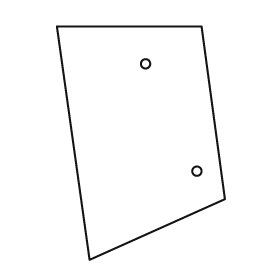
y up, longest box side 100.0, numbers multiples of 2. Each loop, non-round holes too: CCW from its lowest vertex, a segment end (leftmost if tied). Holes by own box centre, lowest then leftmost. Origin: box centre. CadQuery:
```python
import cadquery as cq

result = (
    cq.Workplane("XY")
    .moveTo(-22.0, -50.0)
    .lineTo(36.0, -24.0)
    .lineTo(26.0, 50.0)
    .lineTo(-36.0, 50.0)
    .close()
    .moveTo(24.0, -12.0)
    .circle(2.0)
    .moveTo(2.0, 34.0)
    .circle(2.0)
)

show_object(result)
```